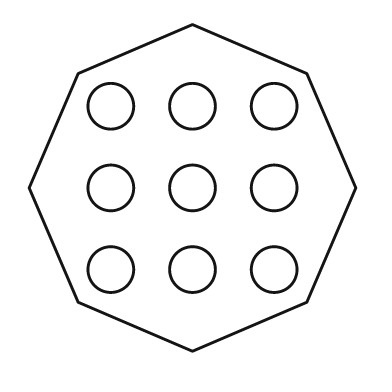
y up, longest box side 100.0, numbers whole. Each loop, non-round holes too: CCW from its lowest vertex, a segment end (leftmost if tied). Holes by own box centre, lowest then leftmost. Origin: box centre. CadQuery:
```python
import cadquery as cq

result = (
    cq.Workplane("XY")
    .moveTo(0.0, -50.0)
    .lineTo(35.0, -35.0)
    .lineTo(50.0, 0.0)
    .lineTo(35.0, 35.0)
    .lineTo(0.0, 50.0)
    .lineTo(-35.0, 35.0)
    .lineTo(-50.0, 0.0)
    .lineTo(-35.0, -35.0)
    .close()
    .moveTo(-25.0, -25.0)
    .circle(7.0)
    .moveTo(0.0, -25.0)
    .circle(7.0)
    .moveTo(25.0, -25.0)
    .circle(7.0)
    .moveTo(-25.0, 0.0)
    .circle(7.0)
    .moveTo(0.0, 0.0)
    .circle(7.0)
    .moveTo(25.0, 0.0)
    .circle(7.0)
    .moveTo(-25.0, 25.0)
    .circle(7.0)
    .moveTo(0.0, 25.0)
    .circle(7.0)
    .moveTo(25.0, 25.0)
    .circle(7.0)
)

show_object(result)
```